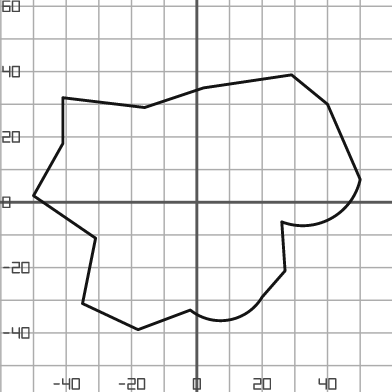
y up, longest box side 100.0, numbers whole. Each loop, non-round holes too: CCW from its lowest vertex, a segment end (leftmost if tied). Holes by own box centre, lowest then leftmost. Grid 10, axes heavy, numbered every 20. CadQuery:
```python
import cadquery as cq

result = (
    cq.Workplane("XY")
    .moveTo(-18.0, -39.0)
    .lineTo(-2.0, -33.0)
    .threePointArc((10.0, -36.0), (20.0, -29.0))
    .lineTo(27.0, -21.0)
    .lineTo(26.0, -6.0)
    .threePointArc((41.0, -5.0), (50.0, 7.0))
    .lineTo(40.0, 30.0)
    .lineTo(29.0, 39.0)
    .lineTo(2.0, 35.0)
    .lineTo(-16.0, 29.0)
    .lineTo(-41.0, 32.0)
    .lineTo(-41.0, 18.0)
    .lineTo(-50.0, 2.0)
    .lineTo(-31.0, -11.0)
    .lineTo(-35.0, -31.0)
    .close()
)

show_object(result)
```